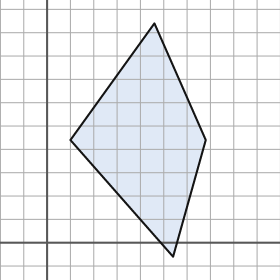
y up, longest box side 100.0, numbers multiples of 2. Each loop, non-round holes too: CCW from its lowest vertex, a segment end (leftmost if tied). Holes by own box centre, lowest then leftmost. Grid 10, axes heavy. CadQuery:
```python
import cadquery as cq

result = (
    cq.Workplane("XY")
    .moveTo(54.0, -6.0)
    .lineTo(68.0, 44.0)
    .lineTo(46.0, 94.0)
    .lineTo(10.0, 44.0)
    .close()
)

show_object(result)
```